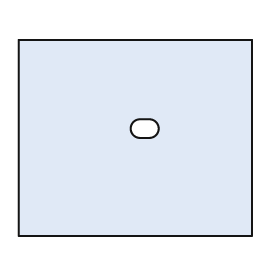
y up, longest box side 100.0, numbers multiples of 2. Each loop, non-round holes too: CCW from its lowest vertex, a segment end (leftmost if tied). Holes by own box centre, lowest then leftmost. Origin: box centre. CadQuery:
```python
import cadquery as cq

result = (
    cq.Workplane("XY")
    .moveTo(-50.0, -42.0)
    .lineTo(50.0, -42.0)
    .lineTo(50.0, 42.0)
    .lineTo(-50.0, 42.0)
    .close()
    .moveTo(2.0, 0.0)
    .lineTo(6.0, 0.0)
    .threePointArc((10.0, 4.0), (6.0, 8.0))
    .lineTo(2.0, 8.0)
    .threePointArc((-2.0, 4.0), (2.0, 0.0))
    .close()
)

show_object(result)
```